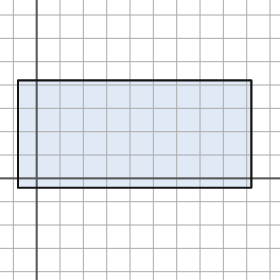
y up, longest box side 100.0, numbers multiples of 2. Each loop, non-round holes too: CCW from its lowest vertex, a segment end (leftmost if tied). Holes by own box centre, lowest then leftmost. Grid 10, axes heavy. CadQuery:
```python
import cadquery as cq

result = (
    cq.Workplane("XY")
    .moveTo(-8.0, -4.0)
    .lineTo(92.0, -4.0)
    .lineTo(92.0, 42.0)
    .lineTo(-8.0, 42.0)
    .close()
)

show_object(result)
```